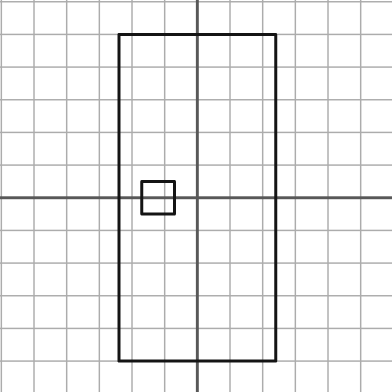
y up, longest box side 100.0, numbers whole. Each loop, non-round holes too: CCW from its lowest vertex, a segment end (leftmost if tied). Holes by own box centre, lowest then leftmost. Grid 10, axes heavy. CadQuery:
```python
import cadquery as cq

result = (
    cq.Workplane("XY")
    .moveTo(-24.0, -50.0)
    .lineTo(24.0, -50.0)
    .lineTo(24.0, 50.0)
    .lineTo(-24.0, 50.0)
    .close()
    .moveTo(-17.0, -5.0)
    .lineTo(-7.0, -5.0)
    .lineTo(-7.0, 5.0)
    .lineTo(-17.0, 5.0)
    .close()
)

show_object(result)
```